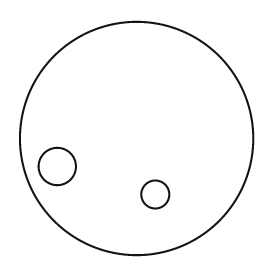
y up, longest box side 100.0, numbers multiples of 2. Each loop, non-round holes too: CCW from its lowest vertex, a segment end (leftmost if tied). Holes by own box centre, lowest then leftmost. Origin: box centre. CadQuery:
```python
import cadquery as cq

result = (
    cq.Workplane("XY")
    .moveTo(0.0, 0.0)
    .circle(50.0)
    .moveTo(8.0, -24.0)
    .circle(6.0)
    .moveTo(-34.0, -12.0)
    .circle(8.0)
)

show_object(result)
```